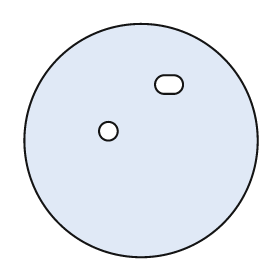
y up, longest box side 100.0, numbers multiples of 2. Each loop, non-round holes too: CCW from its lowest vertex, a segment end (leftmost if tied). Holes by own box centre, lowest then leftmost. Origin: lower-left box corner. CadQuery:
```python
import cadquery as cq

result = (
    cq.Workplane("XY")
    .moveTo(50.0, 50.0)
    .circle(50.0)
    .moveTo(36.0, 54.0)
    .circle(4.0)
    .moveTo(60.0, 70.0)
    .lineTo(64.0, 70.0)
    .threePointArc((68.0, 74.0), (64.0, 78.0))
    .lineTo(60.0, 78.0)
    .threePointArc((56.0, 74.0), (60.0, 70.0))
    .close()
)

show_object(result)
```